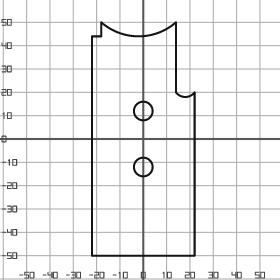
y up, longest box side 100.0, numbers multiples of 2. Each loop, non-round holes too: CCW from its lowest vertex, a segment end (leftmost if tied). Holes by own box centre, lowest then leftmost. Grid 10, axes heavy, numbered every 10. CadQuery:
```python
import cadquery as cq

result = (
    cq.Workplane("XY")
    .moveTo(-22.0, -50.0)
    .lineTo(22.0, -50.0)
    .lineTo(22.0, 20.0)
    .threePointArc((18.0, 18.0), (14.0, 20.0))
    .lineTo(14.0, 50.0)
    .threePointArc((-2.0, 44.0), (-18.0, 50.0))
    .lineTo(-18.0, 44.0)
    .lineTo(-22.0, 44.0)
    .close()
    .moveTo(0.0, -12.0)
    .circle(4.0)
    .moveTo(0.0, 12.0)
    .circle(4.0)
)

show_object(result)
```